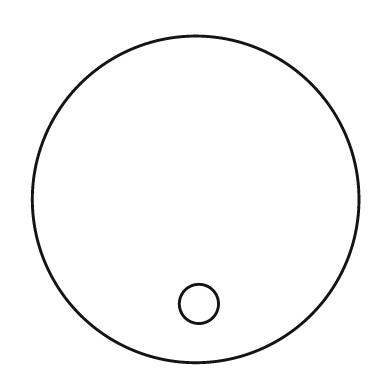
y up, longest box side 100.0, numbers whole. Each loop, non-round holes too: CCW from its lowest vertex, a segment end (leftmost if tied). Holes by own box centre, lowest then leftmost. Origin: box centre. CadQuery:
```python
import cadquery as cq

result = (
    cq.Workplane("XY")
    .moveTo(0.0, 0.0)
    .circle(50.0)
    .moveTo(1.0, -32.0)
    .circle(6.0)
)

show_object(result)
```